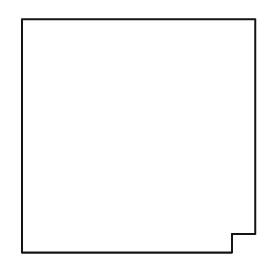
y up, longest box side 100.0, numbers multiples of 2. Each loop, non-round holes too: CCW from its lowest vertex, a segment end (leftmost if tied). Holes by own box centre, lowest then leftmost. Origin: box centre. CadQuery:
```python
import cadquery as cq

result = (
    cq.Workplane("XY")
    .moveTo(-50.0, -50.0)
    .lineTo(40.0, -50.0)
    .lineTo(40.0, -42.0)
    .lineTo(50.0, -42.0)
    .lineTo(50.0, 50.0)
    .lineTo(-50.0, 50.0)
    .close()
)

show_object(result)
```